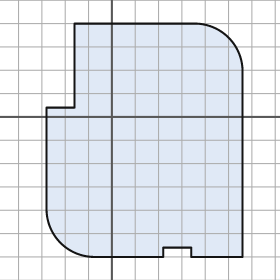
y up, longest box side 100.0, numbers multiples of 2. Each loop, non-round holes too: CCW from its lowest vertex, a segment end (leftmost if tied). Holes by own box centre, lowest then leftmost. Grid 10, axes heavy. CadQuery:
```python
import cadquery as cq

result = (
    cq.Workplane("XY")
    .moveTo(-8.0, -60.0)
    .lineTo(22.0, -60.0)
    .lineTo(22.0, -56.0)
    .lineTo(34.0, -56.0)
    .lineTo(34.0, -60.0)
    .lineTo(56.0, -60.0)
    .lineTo(56.0, 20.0)
    .threePointArc((50.0, 34.0), (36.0, 40.0))
    .lineTo(-16.0, 40.0)
    .lineTo(-16.0, 4.0)
    .lineTo(-28.0, 4.0)
    .lineTo(-28.0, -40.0)
    .threePointArc((-22.0, -54.0), (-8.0, -60.0))
    .close()
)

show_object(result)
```